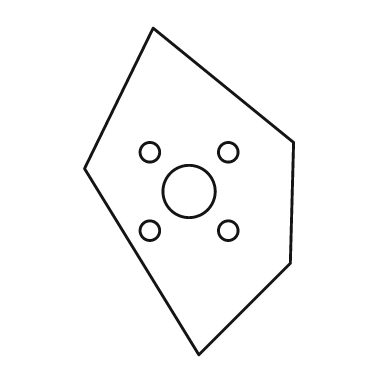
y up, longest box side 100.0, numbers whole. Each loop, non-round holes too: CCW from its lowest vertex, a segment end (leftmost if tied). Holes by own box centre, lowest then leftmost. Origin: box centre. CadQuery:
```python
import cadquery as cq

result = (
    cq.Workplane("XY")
    .moveTo(3.0, -50.0)
    .lineTo(31.0, -22.0)
    .lineTo(32.0, 15.0)
    .lineTo(-11.0, 50.0)
    .lineTo(-32.0, 7.0)
    .close()
    .moveTo(-12.0, -12.0)
    .circle(3.0)
    .moveTo(12.0, -12.0)
    .circle(3.0)
    .moveTo(0.0, 0.0)
    .circle(8.0)
    .moveTo(-12.0, 12.0)
    .circle(3.0)
    .moveTo(12.0, 12.0)
    .circle(3.0)
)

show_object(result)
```